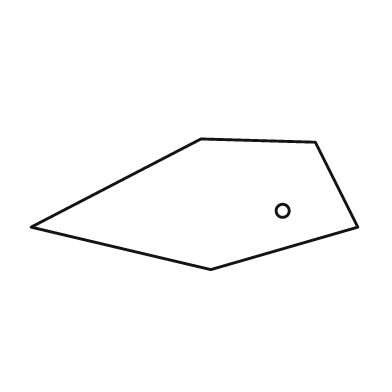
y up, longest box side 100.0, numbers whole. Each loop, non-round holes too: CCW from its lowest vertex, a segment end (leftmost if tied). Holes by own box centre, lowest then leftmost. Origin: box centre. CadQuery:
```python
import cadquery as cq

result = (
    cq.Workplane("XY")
    .moveTo(5.0, -20.0)
    .lineTo(50.0, -7.0)
    .lineTo(37.0, 19.0)
    .lineTo(2.0, 20.0)
    .lineTo(-50.0, -7.0)
    .close()
    .moveTo(27.0, -2.0)
    .circle(2.0)
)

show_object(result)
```